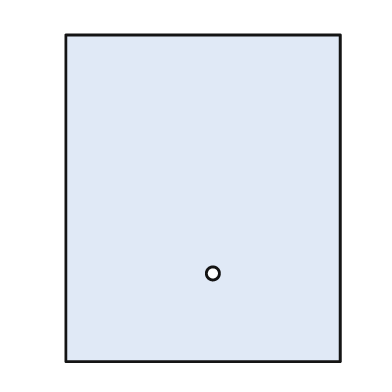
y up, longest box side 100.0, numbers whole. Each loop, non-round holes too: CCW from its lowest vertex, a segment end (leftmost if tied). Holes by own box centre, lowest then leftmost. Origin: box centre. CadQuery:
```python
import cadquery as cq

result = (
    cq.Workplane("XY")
    .moveTo(-42.0, -50.0)
    .lineTo(42.0, -50.0)
    .lineTo(42.0, 50.0)
    .lineTo(-42.0, 50.0)
    .close()
    .moveTo(3.0, -23.0)
    .circle(2.0)
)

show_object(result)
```